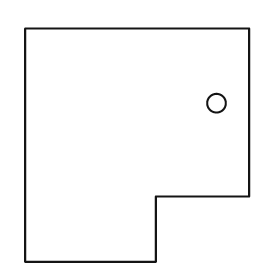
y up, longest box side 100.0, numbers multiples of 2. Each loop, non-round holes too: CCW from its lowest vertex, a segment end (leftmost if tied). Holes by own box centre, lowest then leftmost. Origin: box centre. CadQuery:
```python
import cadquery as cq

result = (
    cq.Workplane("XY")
    .moveTo(-48.0, -50.0)
    .lineTo(8.0, -50.0)
    .lineTo(8.0, -22.0)
    .lineTo(48.0, -22.0)
    .lineTo(48.0, 50.0)
    .lineTo(-48.0, 50.0)
    .close()
    .moveTo(34.0, 18.0)
    .circle(4.0)
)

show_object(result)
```